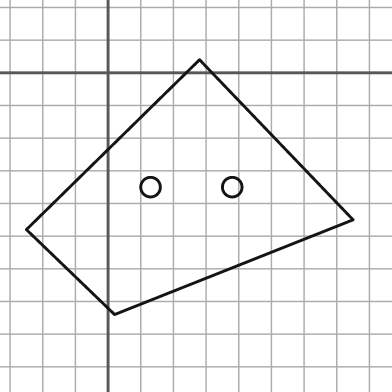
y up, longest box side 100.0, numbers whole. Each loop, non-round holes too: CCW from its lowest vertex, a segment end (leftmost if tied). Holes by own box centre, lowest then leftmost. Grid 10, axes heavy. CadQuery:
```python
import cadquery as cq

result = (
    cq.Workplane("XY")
    .moveTo(2.0, -74.0)
    .lineTo(75.0, -45.0)
    .lineTo(28.0, 4.0)
    .lineTo(-25.0, -48.0)
    .close()
    .moveTo(13.0, -35.0)
    .circle(3.0)
    .moveTo(38.0, -35.0)
    .circle(3.0)
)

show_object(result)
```